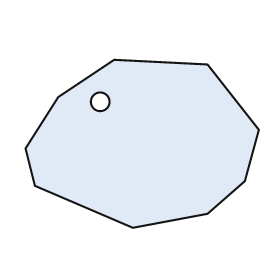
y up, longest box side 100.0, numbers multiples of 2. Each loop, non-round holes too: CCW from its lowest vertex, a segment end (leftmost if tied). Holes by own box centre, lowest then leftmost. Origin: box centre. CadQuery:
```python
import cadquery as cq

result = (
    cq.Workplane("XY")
    .moveTo(-4.0, -36.0)
    .lineTo(28.0, -30.0)
    .lineTo(44.0, -16.0)
    .lineTo(50.0, 6.0)
    .lineTo(28.0, 34.0)
    .lineTo(-12.0, 36.0)
    .lineTo(-36.0, 20.0)
    .lineTo(-50.0, -2.0)
    .lineTo(-46.0, -18.0)
    .close()
    .moveTo(-18.0, 18.0)
    .circle(4.0)
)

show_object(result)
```